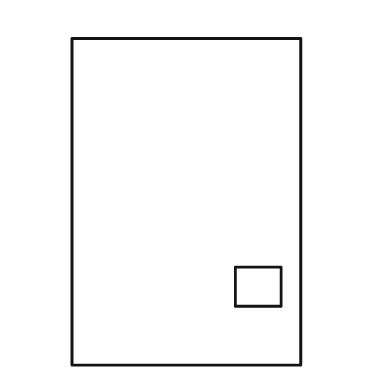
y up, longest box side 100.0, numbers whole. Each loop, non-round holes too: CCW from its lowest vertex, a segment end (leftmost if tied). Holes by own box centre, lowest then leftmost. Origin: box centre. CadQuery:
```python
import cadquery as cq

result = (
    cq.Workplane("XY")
    .moveTo(-35.0, -50.0)
    .lineTo(35.0, -50.0)
    .lineTo(35.0, 50.0)
    .lineTo(-35.0, 50.0)
    .close()
    .moveTo(15.0, -32.0)
    .lineTo(29.0, -32.0)
    .lineTo(29.0, -20.0)
    .lineTo(15.0, -20.0)
    .close()
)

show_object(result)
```